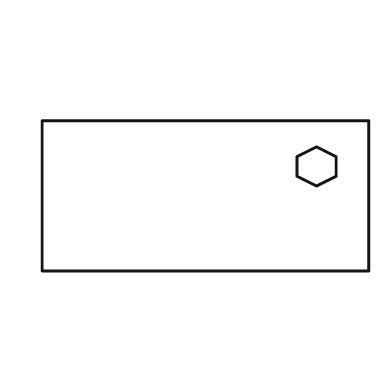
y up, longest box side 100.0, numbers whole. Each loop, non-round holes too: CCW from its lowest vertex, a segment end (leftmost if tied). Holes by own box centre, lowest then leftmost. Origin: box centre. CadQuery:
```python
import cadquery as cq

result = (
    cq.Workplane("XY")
    .moveTo(-50.0, -23.0)
    .lineTo(50.0, -23.0)
    .lineTo(50.0, 23.0)
    .lineTo(-50.0, 23.0)
    .close()
    .moveTo(34.0, 3.0)
    .lineTo(40.0, 6.0)
    .lineTo(40.0, 12.0)
    .lineTo(34.0, 15.0)
    .lineTo(28.0, 12.0)
    .lineTo(28.0, 6.0)
    .close()
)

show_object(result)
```